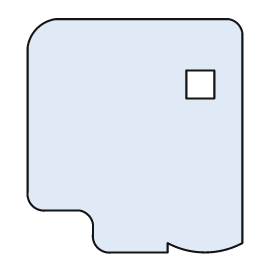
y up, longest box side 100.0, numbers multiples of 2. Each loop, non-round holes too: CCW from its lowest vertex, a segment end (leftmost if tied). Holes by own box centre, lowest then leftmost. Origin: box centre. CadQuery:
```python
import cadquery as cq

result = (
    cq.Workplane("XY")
    .moveTo(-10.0, -50.0)
    .lineTo(14.0, -50.0)
    .lineTo(14.0, -46.0)
    .threePointArc((30.0, -50.0), (46.0, -46.0))
    .lineTo(46.0, 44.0)
    .threePointArc((44.0, 48.0), (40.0, 50.0))
    .lineTo(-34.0, 50.0)
    .threePointArc((-42.0, 46.0), (-46.0, 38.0))
    .lineTo(-46.0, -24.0)
    .threePointArc((-44.0, -30.0), (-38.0, -32.0))
    .lineTo(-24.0, -32.0)
    .threePointArc((-20.0, -34.0), (-18.0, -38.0))
    .lineTo(-18.0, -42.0)
    .threePointArc((-16.0, -48.0), (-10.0, -50.0))
    .close()
    .moveTo(22.0, 16.0)
    .lineTo(34.0, 16.0)
    .lineTo(34.0, 28.0)
    .lineTo(22.0, 28.0)
    .close()
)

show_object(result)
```